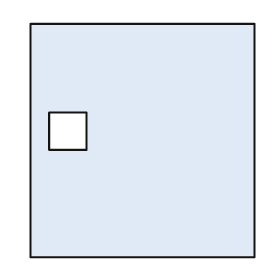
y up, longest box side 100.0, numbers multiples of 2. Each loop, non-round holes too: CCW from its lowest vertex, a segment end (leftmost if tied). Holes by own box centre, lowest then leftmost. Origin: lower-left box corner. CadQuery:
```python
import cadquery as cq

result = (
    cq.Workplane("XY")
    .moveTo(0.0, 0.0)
    .lineTo(96.0, 0.0)
    .lineTo(96.0, 100.0)
    .lineTo(0.0, 100.0)
    .close()
    .moveTo(8.0, 46.0)
    .lineTo(24.0, 46.0)
    .lineTo(24.0, 62.0)
    .lineTo(8.0, 62.0)
    .close()
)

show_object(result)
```